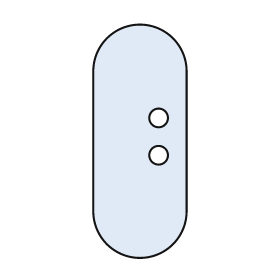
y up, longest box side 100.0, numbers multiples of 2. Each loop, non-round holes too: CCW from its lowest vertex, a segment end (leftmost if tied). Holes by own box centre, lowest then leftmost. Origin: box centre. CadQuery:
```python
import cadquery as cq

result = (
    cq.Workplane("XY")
    .moveTo(-20.0, -30.0)
    .threePointArc((0.0, -50.0), (20.0, -30.0))
    .lineTo(20.0, 30.0)
    .threePointArc((0.0, 50.0), (-20.0, 30.0))
    .close()
    .moveTo(8.0, -6.0)
    .circle(4.0)
    .moveTo(8.0, 10.0)
    .circle(4.0)
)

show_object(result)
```